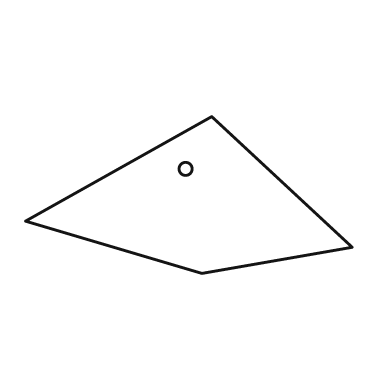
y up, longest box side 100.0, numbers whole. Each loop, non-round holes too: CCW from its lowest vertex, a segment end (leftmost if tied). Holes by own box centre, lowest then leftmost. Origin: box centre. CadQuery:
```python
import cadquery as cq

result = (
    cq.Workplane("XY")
    .moveTo(4.0, -24.0)
    .lineTo(50.0, -16.0)
    .lineTo(7.0, 24.0)
    .lineTo(-50.0, -8.0)
    .close()
    .moveTo(-1.0, 8.0)
    .circle(2.0)
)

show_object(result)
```